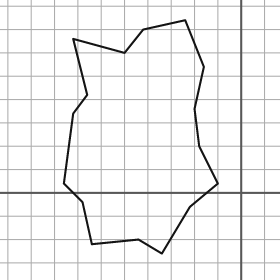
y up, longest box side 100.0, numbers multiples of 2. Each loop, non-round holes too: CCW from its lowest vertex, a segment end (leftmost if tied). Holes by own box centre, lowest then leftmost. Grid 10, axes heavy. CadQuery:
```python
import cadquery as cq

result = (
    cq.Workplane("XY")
    .moveTo(-34.0, -26.0)
    .lineTo(-22.0, -6.0)
    .lineTo(-10.0, 4.0)
    .lineTo(-18.0, 20.0)
    .lineTo(-20.0, 36.0)
    .lineTo(-16.0, 54.0)
    .lineTo(-24.0, 74.0)
    .lineTo(-42.0, 70.0)
    .lineTo(-50.0, 60.0)
    .lineTo(-72.0, 66.0)
    .lineTo(-66.0, 42.0)
    .lineTo(-72.0, 34.0)
    .lineTo(-76.0, 4.0)
    .lineTo(-68.0, -4.0)
    .lineTo(-64.0, -22.0)
    .lineTo(-44.0, -20.0)
    .close()
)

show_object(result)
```